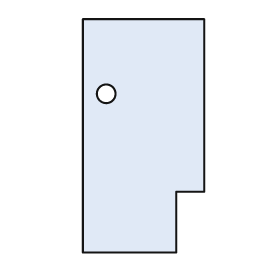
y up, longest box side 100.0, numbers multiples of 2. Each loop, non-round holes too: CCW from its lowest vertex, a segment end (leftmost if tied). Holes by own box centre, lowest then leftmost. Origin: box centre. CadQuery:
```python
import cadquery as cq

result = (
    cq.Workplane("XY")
    .moveTo(-26.0, -50.0)
    .lineTo(14.0, -50.0)
    .lineTo(14.0, -24.0)
    .lineTo(26.0, -24.0)
    .lineTo(26.0, 50.0)
    .lineTo(-26.0, 50.0)
    .close()
    .moveTo(-16.0, 18.0)
    .circle(4.0)
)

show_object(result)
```